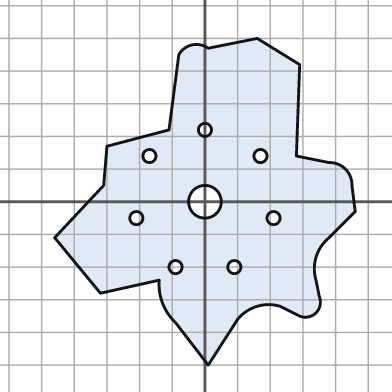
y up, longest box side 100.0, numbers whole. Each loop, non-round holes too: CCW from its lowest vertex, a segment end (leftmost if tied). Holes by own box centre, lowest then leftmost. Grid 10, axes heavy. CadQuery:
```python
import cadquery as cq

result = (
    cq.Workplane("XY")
    .moveTo(1.0, -50.0)
    .lineTo(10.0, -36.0)
    .threePointArc((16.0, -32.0), (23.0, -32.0))
    .lineTo(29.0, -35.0)
    .threePointArc((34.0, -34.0), (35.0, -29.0))
    .lineTo(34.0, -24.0)
    .threePointArc((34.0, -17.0), (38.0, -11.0))
    .lineTo(46.0, -3.0)
    .lineTo(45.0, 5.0)
    .threePointArc((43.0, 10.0), (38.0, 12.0))
    .lineTo(28.0, 14.0)
    .lineTo(29.0, 42.0)
    .lineTo(16.0, 50.0)
    .lineTo(1.0, 47.0)
    .threePointArc((-4.0, 48.0), (-8.0, 45.0))
    .lineTo(-11.0, 22.0)
    .lineTo(-30.0, 17.0)
    .lineTo(-31.0, 5.0)
    .lineTo(-46.0, -11.0)
    .lineTo(-32.0, -28.0)
    .lineTo(-14.0, -24.0)
    .threePointArc((-13.0, -31.0), (-9.0, -37.0))
    .close()
    .moveTo(-9.0, -20.0)
    .circle(2.0)
    .moveTo(9.0, -20.0)
    .circle(2.0)
    .moveTo(-21.0, -5.0)
    .circle(2.0)
    .moveTo(21.0, -5.0)
    .circle(2.0)
    .moveTo(0.0, 0.0)
    .circle(5.0)
    .moveTo(-17.0, 14.0)
    .circle(2.0)
    .moveTo(17.0, 14.0)
    .circle(2.0)
    .moveTo(0.0, 22.0)
    .circle(2.0)
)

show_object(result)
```